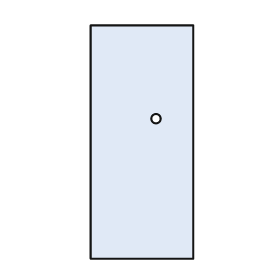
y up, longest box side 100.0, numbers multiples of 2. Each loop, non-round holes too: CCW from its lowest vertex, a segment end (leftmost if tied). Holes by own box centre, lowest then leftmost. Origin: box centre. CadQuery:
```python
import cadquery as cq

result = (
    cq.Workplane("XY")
    .moveTo(-22.0, -50.0)
    .lineTo(22.0, -50.0)
    .lineTo(22.0, 50.0)
    .lineTo(-22.0, 50.0)
    .close()
    .moveTo(6.0, 10.0)
    .circle(2.0)
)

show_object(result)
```